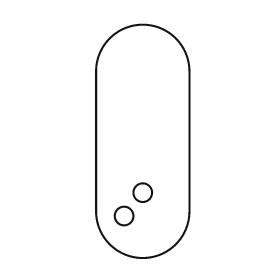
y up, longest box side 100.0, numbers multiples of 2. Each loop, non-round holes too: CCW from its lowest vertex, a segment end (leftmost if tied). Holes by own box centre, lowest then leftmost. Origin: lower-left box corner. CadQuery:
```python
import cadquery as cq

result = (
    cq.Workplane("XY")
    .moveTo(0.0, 20.0)
    .threePointArc((20.0, 0.0), (40.0, 20.0))
    .lineTo(40.0, 80.0)
    .threePointArc((20.0, 100.0), (0.0, 80.0))
    .close()
    .moveTo(12.0, 18.0)
    .circle(4.0)
    .moveTo(20.0, 28.0)
    .circle(4.0)
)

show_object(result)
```